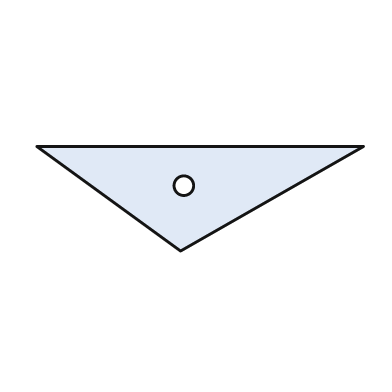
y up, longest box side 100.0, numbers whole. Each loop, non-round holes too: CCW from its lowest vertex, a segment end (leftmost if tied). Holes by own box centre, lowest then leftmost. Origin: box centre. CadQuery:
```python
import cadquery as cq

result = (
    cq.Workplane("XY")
    .moveTo(-6.0, -16.0)
    .lineTo(50.0, 16.0)
    .lineTo(-50.0, 16.0)
    .close()
    .moveTo(-5.0, 4.0)
    .circle(3.0)
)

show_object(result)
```